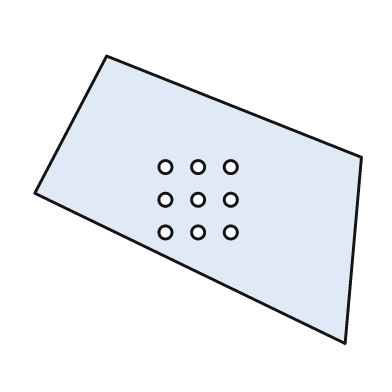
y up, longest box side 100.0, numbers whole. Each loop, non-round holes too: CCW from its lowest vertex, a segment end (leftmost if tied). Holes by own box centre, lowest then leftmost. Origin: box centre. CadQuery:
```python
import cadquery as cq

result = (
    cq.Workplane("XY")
    .moveTo(45.0, -44.0)
    .lineTo(50.0, 13.0)
    .lineTo(-28.0, 44.0)
    .lineTo(-50.0, 2.0)
    .close()
    .moveTo(-10.0, -10.0)
    .circle(2.0)
    .moveTo(0.0, -10.0)
    .circle(2.0)
    .moveTo(10.0, -10.0)
    .circle(2.0)
    .moveTo(-10.0, 0.0)
    .circle(2.0)
    .moveTo(0.0, 0.0)
    .circle(2.0)
    .moveTo(10.0, 0.0)
    .circle(2.0)
    .moveTo(-10.0, 10.0)
    .circle(2.0)
    .moveTo(0.0, 10.0)
    .circle(2.0)
    .moveTo(10.0, 10.0)
    .circle(2.0)
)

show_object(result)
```